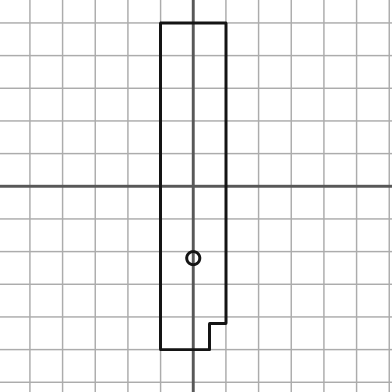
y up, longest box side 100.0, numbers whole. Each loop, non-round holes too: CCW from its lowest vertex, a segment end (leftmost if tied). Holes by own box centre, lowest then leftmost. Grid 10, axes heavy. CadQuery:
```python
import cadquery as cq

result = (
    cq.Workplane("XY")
    .moveTo(-10.0, -50.0)
    .lineTo(5.0, -50.0)
    .lineTo(5.0, -42.0)
    .lineTo(10.0, -42.0)
    .lineTo(10.0, 50.0)
    .lineTo(-10.0, 50.0)
    .close()
    .moveTo(0.0, -22.0)
    .circle(2.0)
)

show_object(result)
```